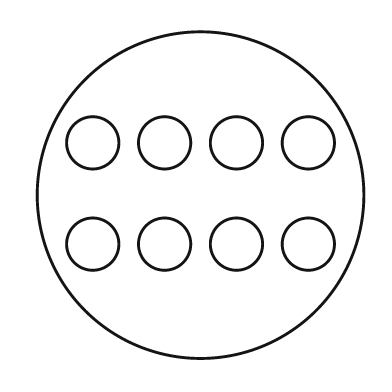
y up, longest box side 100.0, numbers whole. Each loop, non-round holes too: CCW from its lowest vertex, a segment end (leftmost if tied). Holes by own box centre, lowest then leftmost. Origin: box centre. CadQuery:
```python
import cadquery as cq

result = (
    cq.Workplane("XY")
    .moveTo(0.0, 0.0)
    .circle(50.0)
    .moveTo(-33.0, -15.0)
    .circle(8.0)
    .moveTo(-11.0, -15.0)
    .circle(8.0)
    .moveTo(11.0, -15.0)
    .circle(8.0)
    .moveTo(33.0, -15.0)
    .circle(8.0)
    .moveTo(-33.0, 16.0)
    .circle(8.0)
    .moveTo(-11.0, 16.0)
    .circle(8.0)
    .moveTo(11.0, 16.0)
    .circle(8.0)
    .moveTo(33.0, 16.0)
    .circle(8.0)
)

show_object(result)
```